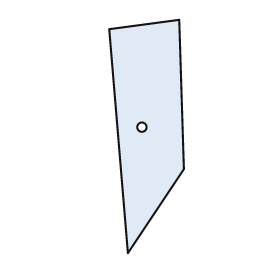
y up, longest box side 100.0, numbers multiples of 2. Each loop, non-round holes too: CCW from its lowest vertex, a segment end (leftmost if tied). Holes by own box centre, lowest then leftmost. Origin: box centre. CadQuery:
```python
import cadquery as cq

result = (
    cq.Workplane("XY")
    .moveTo(-8.0, -50.0)
    .lineTo(16.0, -14.0)
    .lineTo(14.0, 50.0)
    .lineTo(-16.0, 46.0)
    .close()
    .moveTo(-2.0, 4.0)
    .circle(2.0)
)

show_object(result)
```